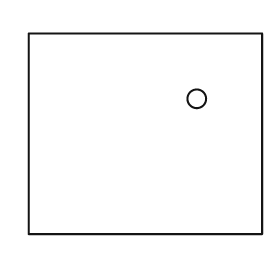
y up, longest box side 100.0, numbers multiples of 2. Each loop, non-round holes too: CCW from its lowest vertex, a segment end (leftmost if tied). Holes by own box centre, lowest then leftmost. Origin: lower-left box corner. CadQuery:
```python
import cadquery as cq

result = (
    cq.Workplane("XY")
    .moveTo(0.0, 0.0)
    .lineTo(100.0, 0.0)
    .lineTo(100.0, 86.0)
    .lineTo(0.0, 86.0)
    .close()
    .moveTo(72.0, 58.0)
    .circle(4.0)
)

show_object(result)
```